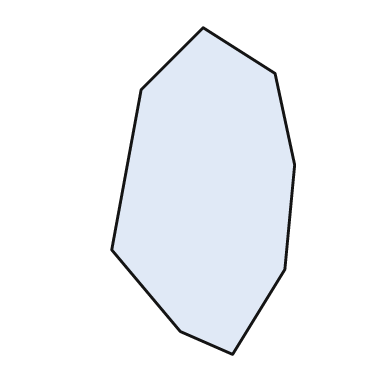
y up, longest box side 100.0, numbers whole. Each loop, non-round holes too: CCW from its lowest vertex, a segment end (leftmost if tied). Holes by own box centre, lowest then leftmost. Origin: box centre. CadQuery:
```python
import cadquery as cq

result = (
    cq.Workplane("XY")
    .moveTo(9.0, -50.0)
    .lineTo(25.0, -24.0)
    .lineTo(28.0, 8.0)
    .lineTo(22.0, 36.0)
    .lineTo(0.0, 50.0)
    .lineTo(-19.0, 31.0)
    .lineTo(-28.0, -18.0)
    .lineTo(-7.0, -43.0)
    .close()
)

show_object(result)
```